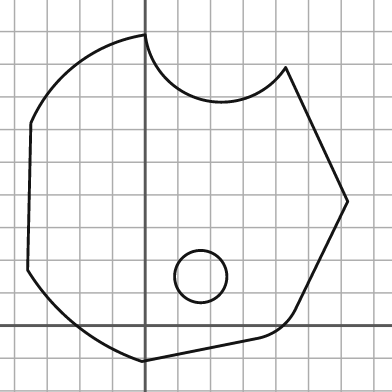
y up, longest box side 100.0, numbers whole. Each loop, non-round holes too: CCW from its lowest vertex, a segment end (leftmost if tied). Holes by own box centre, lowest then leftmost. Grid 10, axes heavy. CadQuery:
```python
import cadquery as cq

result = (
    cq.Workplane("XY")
    .moveTo(-1.0, -11.0)
    .lineTo(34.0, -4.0)
    .threePointArc((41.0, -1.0), (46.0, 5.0))
    .lineTo(62.0, 38.0)
    .lineTo(43.0, 79.0)
    .threePointArc((18.0, 69.0), (0.0, 89.0))
    .threePointArc((-21.0, 80.0), (-35.0, 62.0))
    .lineTo(-36.0, 17.0)
    .threePointArc((-21.0, 0.0), (-1.0, -11.0))
    .close()
    .moveTo(17.0, 15.0)
    .circle(8.0)
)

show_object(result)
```